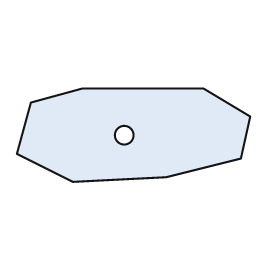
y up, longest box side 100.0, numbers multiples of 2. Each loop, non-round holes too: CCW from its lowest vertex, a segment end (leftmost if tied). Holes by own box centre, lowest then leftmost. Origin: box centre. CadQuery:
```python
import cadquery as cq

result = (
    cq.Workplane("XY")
    .moveTo(-26.0, -20.0)
    .lineTo(14.0, -18.0)
    .lineTo(46.0, -10.0)
    .lineTo(50.0, 8.0)
    .lineTo(30.0, 20.0)
    .lineTo(-22.0, 20.0)
    .lineTo(-44.0, 14.0)
    .lineTo(-50.0, -8.0)
    .close()
    .moveTo(-4.0, 0.0)
    .circle(4.0)
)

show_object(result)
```